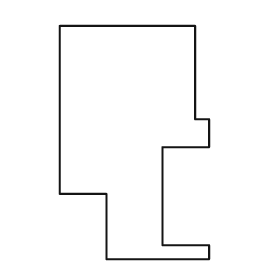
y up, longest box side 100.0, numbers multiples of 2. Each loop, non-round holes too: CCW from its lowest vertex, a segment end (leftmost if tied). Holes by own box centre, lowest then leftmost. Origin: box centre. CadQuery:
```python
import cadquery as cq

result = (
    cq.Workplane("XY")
    .moveTo(-12.0, -50.0)
    .lineTo(32.0, -50.0)
    .lineTo(32.0, -44.0)
    .lineTo(12.0, -44.0)
    .lineTo(12.0, -2.0)
    .lineTo(32.0, -2.0)
    .lineTo(32.0, 10.0)
    .lineTo(26.0, 10.0)
    .lineTo(26.0, 50.0)
    .lineTo(-32.0, 50.0)
    .lineTo(-32.0, -22.0)
    .lineTo(-12.0, -22.0)
    .close()
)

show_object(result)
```